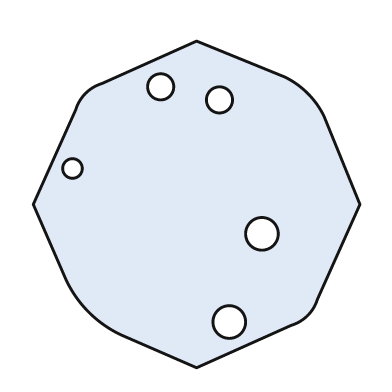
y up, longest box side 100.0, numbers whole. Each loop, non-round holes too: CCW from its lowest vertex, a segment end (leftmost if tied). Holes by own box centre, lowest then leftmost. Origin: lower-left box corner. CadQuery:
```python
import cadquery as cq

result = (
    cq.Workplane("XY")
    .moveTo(50.0, 0.0)
    .lineTo(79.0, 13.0)
    .threePointArc((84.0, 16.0), (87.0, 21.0))
    .lineTo(100.0, 50.0)
    .lineTo(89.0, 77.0)
    .threePointArc((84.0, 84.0), (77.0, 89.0))
    .lineTo(50.0, 100.0)
    .lineTo(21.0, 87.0)
    .threePointArc((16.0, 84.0), (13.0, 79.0))
    .lineTo(0.0, 50.0)
    .lineTo(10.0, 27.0)
    .threePointArc((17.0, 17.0), (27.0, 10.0))
    .close()
    .moveTo(60.0, 14.0)
    .circle(5.0)
    .moveTo(70.0, 41.0)
    .circle(5.0)
    .moveTo(12.0, 61.0)
    .circle(3.0)
    .moveTo(57.0, 82.0)
    .circle(4.0)
    .moveTo(39.0, 86.0)
    .circle(4.0)
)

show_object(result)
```